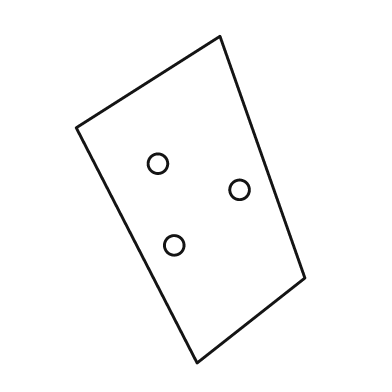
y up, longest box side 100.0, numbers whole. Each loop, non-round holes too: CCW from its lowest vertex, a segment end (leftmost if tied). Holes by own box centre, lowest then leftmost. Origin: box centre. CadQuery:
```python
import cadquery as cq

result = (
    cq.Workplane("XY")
    .moveTo(2.0, -50.0)
    .lineTo(35.0, -24.0)
    .lineTo(9.0, 50.0)
    .lineTo(-35.0, 22.0)
    .close()
    .moveTo(-5.0, -14.0)
    .circle(3.0)
    .moveTo(15.0, 3.0)
    .circle(3.0)
    .moveTo(-10.0, 11.0)
    .circle(3.0)
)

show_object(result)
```